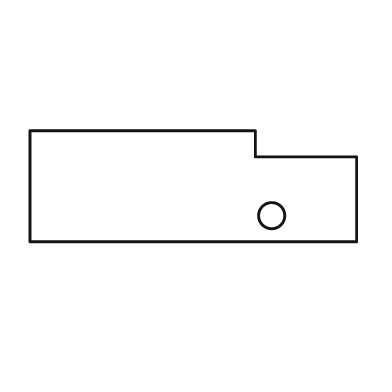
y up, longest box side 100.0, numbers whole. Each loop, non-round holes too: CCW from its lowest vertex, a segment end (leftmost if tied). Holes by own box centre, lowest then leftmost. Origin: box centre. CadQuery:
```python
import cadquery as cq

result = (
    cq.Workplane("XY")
    .moveTo(-50.0, -17.0)
    .lineTo(50.0, -17.0)
    .lineTo(50.0, 9.0)
    .lineTo(19.0, 9.0)
    .lineTo(19.0, 17.0)
    .lineTo(-50.0, 17.0)
    .close()
    .moveTo(24.0, -9.0)
    .circle(4.0)
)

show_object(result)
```